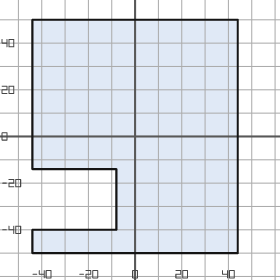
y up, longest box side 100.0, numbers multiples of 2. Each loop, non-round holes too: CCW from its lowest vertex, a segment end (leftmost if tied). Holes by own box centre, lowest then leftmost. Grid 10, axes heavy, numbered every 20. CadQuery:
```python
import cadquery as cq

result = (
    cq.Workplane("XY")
    .moveTo(-44.0, -50.0)
    .lineTo(44.0, -50.0)
    .lineTo(44.0, 50.0)
    .lineTo(-44.0, 50.0)
    .lineTo(-44.0, -14.0)
    .lineTo(-8.0, -14.0)
    .lineTo(-8.0, -40.0)
    .lineTo(-44.0, -40.0)
    .close()
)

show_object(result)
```